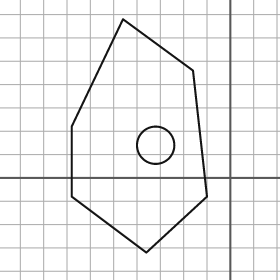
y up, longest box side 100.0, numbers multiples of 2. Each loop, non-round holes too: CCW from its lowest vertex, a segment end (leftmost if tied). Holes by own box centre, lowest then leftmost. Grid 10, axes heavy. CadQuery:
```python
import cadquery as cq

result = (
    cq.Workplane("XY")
    .moveTo(-36.0, -32.0)
    .lineTo(-10.0, -8.0)
    .lineTo(-16.0, 46.0)
    .lineTo(-46.0, 68.0)
    .lineTo(-68.0, 22.0)
    .lineTo(-68.0, -8.0)
    .close()
    .moveTo(-32.0, 14.0)
    .circle(8.0)
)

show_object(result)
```